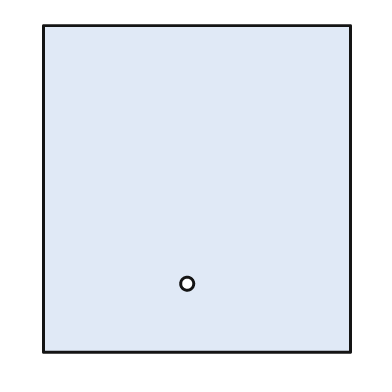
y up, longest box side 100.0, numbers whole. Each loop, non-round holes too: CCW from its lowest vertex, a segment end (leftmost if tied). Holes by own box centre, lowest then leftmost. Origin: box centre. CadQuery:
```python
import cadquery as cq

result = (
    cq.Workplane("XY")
    .moveTo(-47.0, -50.0)
    .lineTo(47.0, -50.0)
    .lineTo(47.0, 50.0)
    .lineTo(-47.0, 50.0)
    .close()
    .moveTo(-3.0, -29.0)
    .circle(2.0)
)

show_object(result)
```